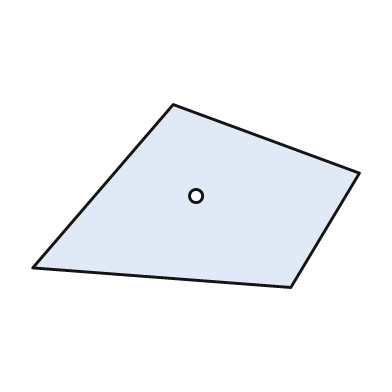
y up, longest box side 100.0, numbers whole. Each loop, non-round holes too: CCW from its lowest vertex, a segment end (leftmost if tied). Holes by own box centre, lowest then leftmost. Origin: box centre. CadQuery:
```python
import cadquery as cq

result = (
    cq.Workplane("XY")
    .moveTo(29.0, -28.0)
    .lineTo(50.0, 7.0)
    .lineTo(-7.0, 28.0)
    .lineTo(-50.0, -22.0)
    .close()
    .moveTo(0.0, 0.0)
    .circle(2.0)
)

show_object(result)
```